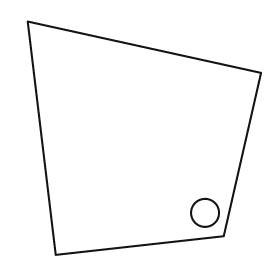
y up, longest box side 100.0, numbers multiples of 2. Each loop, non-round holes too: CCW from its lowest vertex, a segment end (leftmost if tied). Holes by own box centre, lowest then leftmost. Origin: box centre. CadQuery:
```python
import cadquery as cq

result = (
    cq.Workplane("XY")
    .moveTo(-38.0, -50.0)
    .lineTo(34.0, -42.0)
    .lineTo(50.0, 28.0)
    .lineTo(-50.0, 50.0)
    .close()
    .moveTo(26.0, -32.0)
    .circle(6.0)
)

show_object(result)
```